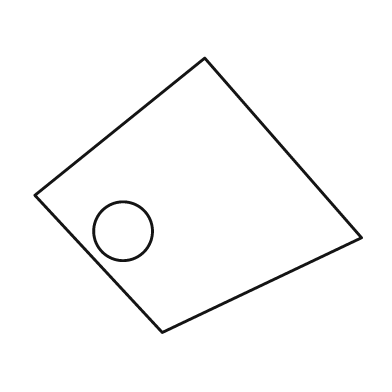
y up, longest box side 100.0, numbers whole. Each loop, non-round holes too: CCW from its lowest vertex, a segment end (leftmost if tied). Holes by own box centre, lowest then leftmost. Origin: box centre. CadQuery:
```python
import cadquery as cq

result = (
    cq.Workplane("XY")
    .moveTo(-11.0, -42.0)
    .lineTo(50.0, -13.0)
    .lineTo(2.0, 42.0)
    .lineTo(-50.0, 0.0)
    .close()
    .moveTo(-23.0, -11.0)
    .circle(9.0)
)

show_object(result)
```